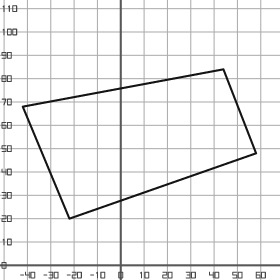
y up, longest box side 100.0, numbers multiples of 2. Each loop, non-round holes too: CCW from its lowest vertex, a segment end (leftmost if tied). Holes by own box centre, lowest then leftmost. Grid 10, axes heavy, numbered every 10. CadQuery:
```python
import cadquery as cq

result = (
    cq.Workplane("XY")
    .moveTo(-22.0, 20.0)
    .lineTo(58.0, 48.0)
    .lineTo(44.0, 84.0)
    .lineTo(-42.0, 68.0)
    .close()
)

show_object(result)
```